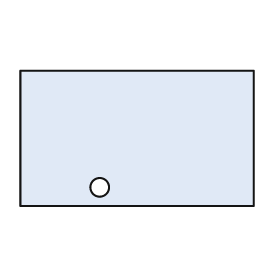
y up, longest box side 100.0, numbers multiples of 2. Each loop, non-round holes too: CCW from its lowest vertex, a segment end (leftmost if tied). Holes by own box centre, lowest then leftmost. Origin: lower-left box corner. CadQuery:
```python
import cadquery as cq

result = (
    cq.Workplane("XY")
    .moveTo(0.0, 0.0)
    .lineTo(100.0, 0.0)
    .lineTo(100.0, 58.0)
    .lineTo(0.0, 58.0)
    .close()
    .moveTo(34.0, 8.0)
    .circle(4.0)
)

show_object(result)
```